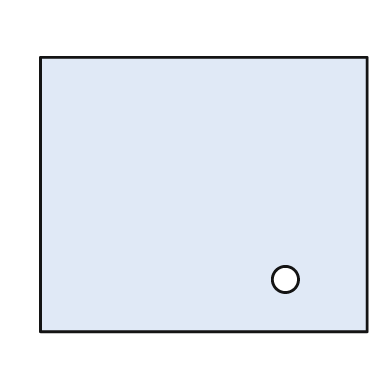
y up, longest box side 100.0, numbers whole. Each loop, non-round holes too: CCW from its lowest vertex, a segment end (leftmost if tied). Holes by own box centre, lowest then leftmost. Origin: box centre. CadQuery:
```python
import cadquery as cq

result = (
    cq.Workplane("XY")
    .moveTo(-50.0, -42.0)
    .lineTo(50.0, -42.0)
    .lineTo(50.0, 42.0)
    .lineTo(-50.0, 42.0)
    .close()
    .moveTo(25.0, -26.0)
    .circle(4.0)
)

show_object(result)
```